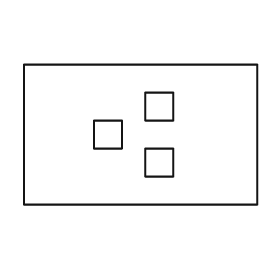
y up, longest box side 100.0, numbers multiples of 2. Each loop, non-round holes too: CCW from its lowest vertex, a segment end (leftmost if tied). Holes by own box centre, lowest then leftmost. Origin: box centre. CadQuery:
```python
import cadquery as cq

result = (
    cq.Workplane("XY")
    .moveTo(-50.0, -30.0)
    .lineTo(50.0, -30.0)
    .lineTo(50.0, 30.0)
    .lineTo(-50.0, 30.0)
    .close()
    .moveTo(2.0, -18.0)
    .lineTo(14.0, -18.0)
    .lineTo(14.0, -6.0)
    .lineTo(2.0, -6.0)
    .close()
    .moveTo(-20.0, -6.0)
    .lineTo(-8.0, -6.0)
    .lineTo(-8.0, 6.0)
    .lineTo(-20.0, 6.0)
    .close()
    .moveTo(2.0, 6.0)
    .lineTo(14.0, 6.0)
    .lineTo(14.0, 18.0)
    .lineTo(2.0, 18.0)
    .close()
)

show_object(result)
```